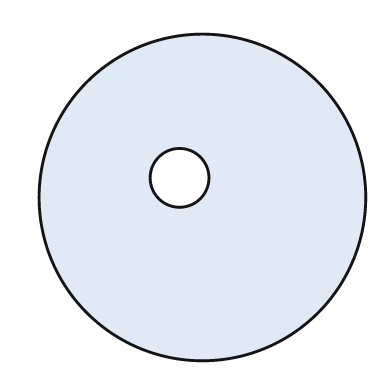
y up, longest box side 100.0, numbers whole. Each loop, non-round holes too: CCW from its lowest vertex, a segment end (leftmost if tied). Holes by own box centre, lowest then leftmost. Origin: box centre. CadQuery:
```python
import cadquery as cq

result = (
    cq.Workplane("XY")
    .moveTo(0.0, 0.0)
    .circle(50.0)
    .moveTo(-7.0, 6.0)
    .circle(9.0)
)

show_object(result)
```